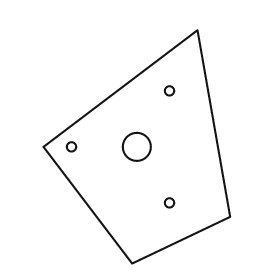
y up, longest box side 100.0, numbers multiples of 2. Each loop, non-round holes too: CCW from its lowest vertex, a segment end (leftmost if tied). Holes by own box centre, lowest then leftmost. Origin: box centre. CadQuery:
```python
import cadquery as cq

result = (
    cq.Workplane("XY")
    .moveTo(-2.0, -50.0)
    .lineTo(40.0, -30.0)
    .lineTo(26.0, 50.0)
    .lineTo(-40.0, 0.0)
    .close()
    .moveTo(14.0, -24.0)
    .circle(2.0)
    .moveTo(-28.0, 0.0)
    .circle(2.0)
    .moveTo(0.0, 0.0)
    .circle(6.0)
    .moveTo(14.0, 24.0)
    .circle(2.0)
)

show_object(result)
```